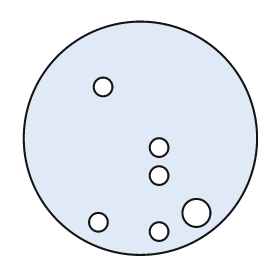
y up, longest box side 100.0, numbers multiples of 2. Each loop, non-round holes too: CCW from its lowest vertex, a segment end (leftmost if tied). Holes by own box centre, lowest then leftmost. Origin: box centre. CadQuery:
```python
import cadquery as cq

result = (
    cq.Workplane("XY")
    .moveTo(0.0, 0.0)
    .circle(50.0)
    .moveTo(8.0, -40.0)
    .circle(4.0)
    .moveTo(-18.0, -36.0)
    .circle(4.0)
    .moveTo(24.0, -32.0)
    .circle(6.0)
    .moveTo(8.0, -16.0)
    .circle(4.0)
    .moveTo(8.0, -4.0)
    .circle(4.0)
    .moveTo(-16.0, 22.0)
    .circle(4.0)
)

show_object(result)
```